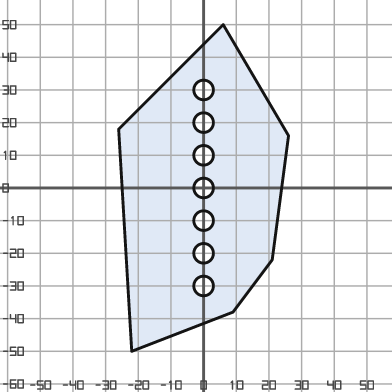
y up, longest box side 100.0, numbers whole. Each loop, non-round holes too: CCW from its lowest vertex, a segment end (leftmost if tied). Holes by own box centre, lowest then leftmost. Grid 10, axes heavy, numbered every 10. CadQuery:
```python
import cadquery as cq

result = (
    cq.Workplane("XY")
    .moveTo(-22.0, -50.0)
    .lineTo(9.0, -38.0)
    .lineTo(21.0, -22.0)
    .lineTo(26.0, 16.0)
    .lineTo(6.0, 50.0)
    .lineTo(-26.0, 18.0)
    .close()
    .moveTo(0.0, -30.0)
    .circle(3.0)
    .moveTo(0.0, -20.0)
    .circle(3.0)
    .moveTo(0.0, -10.0)
    .circle(3.0)
    .moveTo(0.0, 0.0)
    .circle(3.0)
    .moveTo(0.0, 10.0)
    .circle(3.0)
    .moveTo(0.0, 20.0)
    .circle(3.0)
    .moveTo(0.0, 30.0)
    .circle(3.0)
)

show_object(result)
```